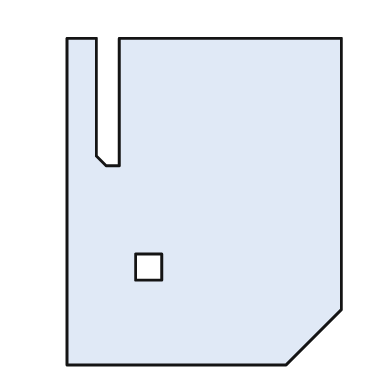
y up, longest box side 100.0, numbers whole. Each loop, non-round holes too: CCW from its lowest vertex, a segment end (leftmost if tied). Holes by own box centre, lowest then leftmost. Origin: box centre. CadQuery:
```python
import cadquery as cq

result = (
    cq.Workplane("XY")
    .moveTo(-42.0, -50.0)
    .lineTo(25.0, -50.0)
    .lineTo(42.0, -33.0)
    .lineTo(42.0, 50.0)
    .lineTo(-26.0, 50.0)
    .lineTo(-26.0, 11.0)
    .lineTo(-30.0, 11.0)
    .lineTo(-33.0, 14.0)
    .lineTo(-33.0, 50.0)
    .lineTo(-42.0, 50.0)
    .close()
    .moveTo(-21.0, -24.0)
    .lineTo(-13.0, -24.0)
    .lineTo(-13.0, -16.0)
    .lineTo(-21.0, -16.0)
    .close()
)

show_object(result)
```